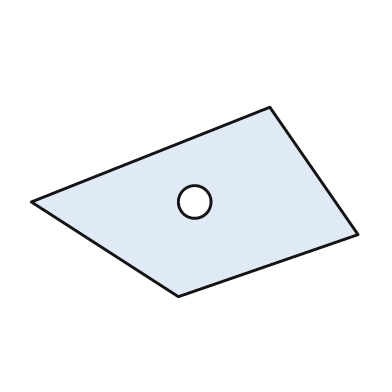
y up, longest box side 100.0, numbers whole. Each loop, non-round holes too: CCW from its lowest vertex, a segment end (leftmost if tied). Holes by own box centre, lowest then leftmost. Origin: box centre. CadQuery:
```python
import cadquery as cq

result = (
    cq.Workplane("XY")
    .moveTo(-5.0, -29.0)
    .lineTo(50.0, -10.0)
    .lineTo(23.0, 29.0)
    .lineTo(-50.0, 0.0)
    .close()
    .moveTo(0.0, 0.0)
    .circle(5.0)
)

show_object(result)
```